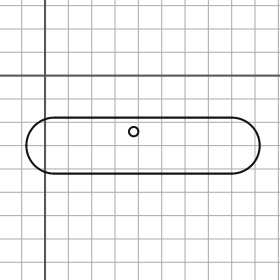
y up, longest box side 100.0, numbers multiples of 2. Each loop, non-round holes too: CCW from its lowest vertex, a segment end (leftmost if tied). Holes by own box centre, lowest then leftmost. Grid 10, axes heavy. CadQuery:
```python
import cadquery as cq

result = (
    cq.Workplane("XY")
    .moveTo(4.0, -42.0)
    .lineTo(80.0, -42.0)
    .threePointArc((92.0, -30.0), (80.0, -18.0))
    .lineTo(4.0, -18.0)
    .threePointArc((-8.0, -30.0), (4.0, -42.0))
    .close()
    .moveTo(38.0, -24.0)
    .circle(2.0)
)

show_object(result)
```